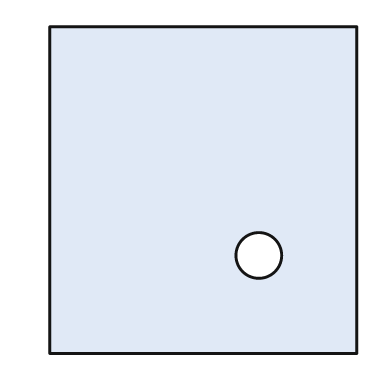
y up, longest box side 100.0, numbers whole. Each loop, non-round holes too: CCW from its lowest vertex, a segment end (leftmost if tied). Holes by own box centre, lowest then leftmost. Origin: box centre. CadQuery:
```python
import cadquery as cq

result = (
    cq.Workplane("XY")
    .moveTo(-47.0, -50.0)
    .lineTo(47.0, -50.0)
    .lineTo(47.0, 50.0)
    .lineTo(-47.0, 50.0)
    .close()
    .moveTo(17.0, -20.0)
    .circle(7.0)
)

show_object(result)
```